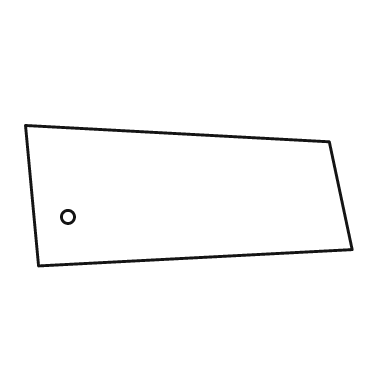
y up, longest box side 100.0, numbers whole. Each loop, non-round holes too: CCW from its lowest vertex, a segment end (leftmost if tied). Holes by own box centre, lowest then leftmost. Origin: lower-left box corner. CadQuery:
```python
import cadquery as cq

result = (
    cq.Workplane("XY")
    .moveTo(4.0, 0.0)
    .lineTo(100.0, 5.0)
    .lineTo(93.0, 38.0)
    .lineTo(0.0, 43.0)
    .close()
    .moveTo(13.0, 15.0)
    .circle(2.0)
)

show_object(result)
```